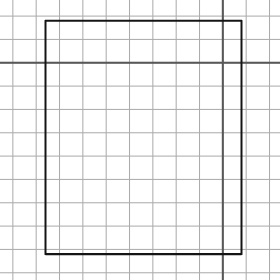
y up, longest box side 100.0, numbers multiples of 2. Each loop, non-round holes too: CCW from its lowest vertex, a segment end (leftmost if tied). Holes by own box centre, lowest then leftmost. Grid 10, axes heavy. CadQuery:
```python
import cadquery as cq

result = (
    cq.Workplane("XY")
    .moveTo(-76.0, -82.0)
    .lineTo(8.0, -82.0)
    .lineTo(8.0, 18.0)
    .lineTo(-76.0, 18.0)
    .close()
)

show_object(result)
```